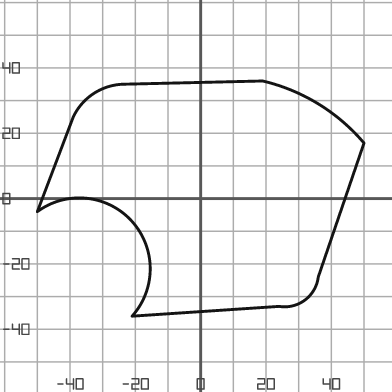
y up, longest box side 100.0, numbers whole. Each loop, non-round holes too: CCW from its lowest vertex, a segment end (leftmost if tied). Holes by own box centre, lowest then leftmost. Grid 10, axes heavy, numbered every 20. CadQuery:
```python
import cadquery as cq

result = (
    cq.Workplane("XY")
    .moveTo(-21.0, -36.0)
    .lineTo(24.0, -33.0)
    .threePointArc((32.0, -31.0), (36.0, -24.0))
    .lineTo(50.0, 17.0)
    .threePointArc((36.0, 29.0), (19.0, 36.0))
    .lineTo(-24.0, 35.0)
    .threePointArc((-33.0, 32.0), (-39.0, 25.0))
    .lineTo(-50.0, -4.0)
    .threePointArc((-21.0, -7.0), (-21.0, -36.0))
    .close()
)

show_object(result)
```